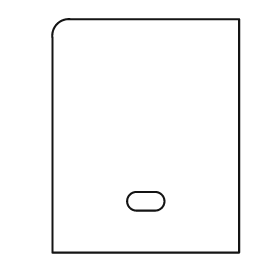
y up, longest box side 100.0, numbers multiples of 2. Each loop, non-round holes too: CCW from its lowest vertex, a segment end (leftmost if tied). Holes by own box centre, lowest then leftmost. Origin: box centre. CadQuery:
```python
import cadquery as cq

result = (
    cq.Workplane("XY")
    .moveTo(-40.0, -50.0)
    .lineTo(40.0, -50.0)
    .lineTo(40.0, 50.0)
    .lineTo(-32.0, 50.0)
    .threePointArc((-38.0, 48.0), (-40.0, 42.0))
    .close()
    .moveTo(-4.0, -32.0)
    .lineTo(4.0, -32.0)
    .threePointArc((8.0, -28.0), (4.0, -24.0))
    .lineTo(-4.0, -24.0)
    .threePointArc((-8.0, -28.0), (-4.0, -32.0))
    .close()
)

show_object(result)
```